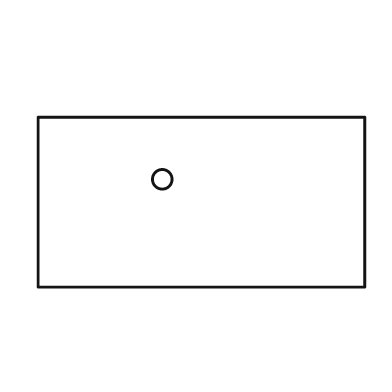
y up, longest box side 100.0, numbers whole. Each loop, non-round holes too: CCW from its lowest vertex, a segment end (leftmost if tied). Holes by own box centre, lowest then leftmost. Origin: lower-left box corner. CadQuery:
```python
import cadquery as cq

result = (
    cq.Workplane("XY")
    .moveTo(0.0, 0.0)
    .lineTo(100.0, 0.0)
    .lineTo(100.0, 52.0)
    .lineTo(0.0, 52.0)
    .close()
    .moveTo(38.0, 33.0)
    .circle(3.0)
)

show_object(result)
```